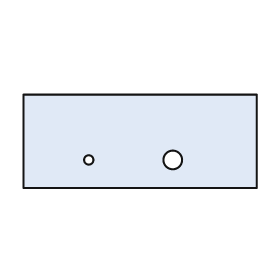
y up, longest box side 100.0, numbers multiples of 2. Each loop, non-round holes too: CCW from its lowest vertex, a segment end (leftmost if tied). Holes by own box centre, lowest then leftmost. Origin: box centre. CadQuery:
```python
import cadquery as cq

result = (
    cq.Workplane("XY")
    .moveTo(-50.0, -20.0)
    .lineTo(50.0, -20.0)
    .lineTo(50.0, 20.0)
    .lineTo(-50.0, 20.0)
    .close()
    .moveTo(-22.0, -8.0)
    .circle(2.0)
    .moveTo(14.0, -8.0)
    .circle(4.0)
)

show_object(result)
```